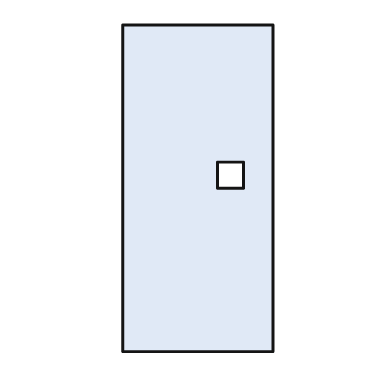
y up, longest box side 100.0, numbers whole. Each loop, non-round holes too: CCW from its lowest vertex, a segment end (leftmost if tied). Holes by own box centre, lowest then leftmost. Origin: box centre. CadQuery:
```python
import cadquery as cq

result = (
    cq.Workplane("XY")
    .moveTo(-23.0, -50.0)
    .lineTo(23.0, -50.0)
    .lineTo(23.0, 50.0)
    .lineTo(-23.0, 50.0)
    .close()
    .moveTo(6.0, 0.0)
    .lineTo(14.0, 0.0)
    .lineTo(14.0, 8.0)
    .lineTo(6.0, 8.0)
    .close()
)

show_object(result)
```